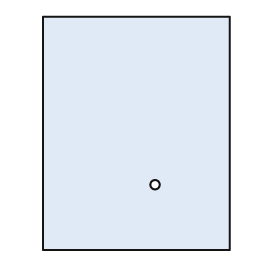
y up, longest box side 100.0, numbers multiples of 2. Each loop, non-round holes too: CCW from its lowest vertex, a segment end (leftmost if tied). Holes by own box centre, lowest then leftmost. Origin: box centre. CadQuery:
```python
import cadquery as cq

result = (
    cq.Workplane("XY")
    .moveTo(-40.0, -50.0)
    .lineTo(40.0, -50.0)
    .lineTo(40.0, 50.0)
    .lineTo(-40.0, 50.0)
    .close()
    .moveTo(8.0, -22.0)
    .circle(2.0)
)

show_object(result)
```